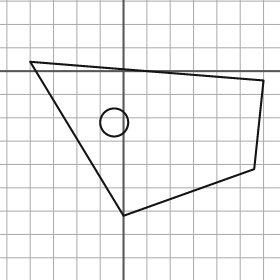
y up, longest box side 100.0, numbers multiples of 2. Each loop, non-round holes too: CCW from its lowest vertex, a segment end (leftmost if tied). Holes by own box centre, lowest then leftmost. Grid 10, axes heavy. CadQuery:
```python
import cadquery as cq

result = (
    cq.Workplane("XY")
    .moveTo(0.0, -62.0)
    .lineTo(56.0, -42.0)
    .lineTo(60.0, -4.0)
    .lineTo(-40.0, 4.0)
    .close()
    .moveTo(-4.0, -22.0)
    .circle(6.0)
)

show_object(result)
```